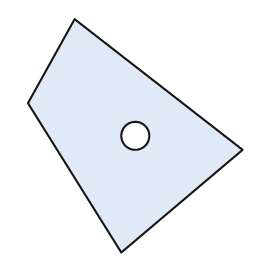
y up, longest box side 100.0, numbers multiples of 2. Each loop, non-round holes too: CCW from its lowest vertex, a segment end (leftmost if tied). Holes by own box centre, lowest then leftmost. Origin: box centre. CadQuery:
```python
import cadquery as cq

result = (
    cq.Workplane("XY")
    .moveTo(-6.0, -50.0)
    .lineTo(46.0, -6.0)
    .lineTo(-26.0, 50.0)
    .lineTo(-46.0, 14.0)
    .close()
    .moveTo(0.0, 0.0)
    .circle(6.0)
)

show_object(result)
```